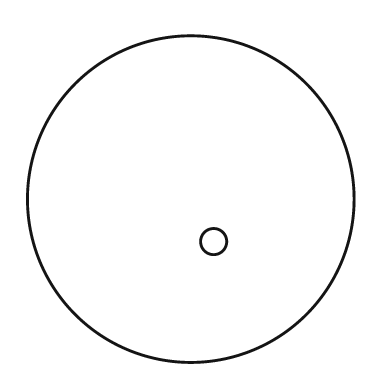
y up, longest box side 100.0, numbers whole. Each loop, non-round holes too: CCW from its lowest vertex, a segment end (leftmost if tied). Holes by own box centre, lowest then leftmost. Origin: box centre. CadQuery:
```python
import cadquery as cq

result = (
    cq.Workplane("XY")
    .moveTo(0.0, 0.0)
    .circle(50.0)
    .moveTo(7.0, -13.0)
    .circle(4.0)
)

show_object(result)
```